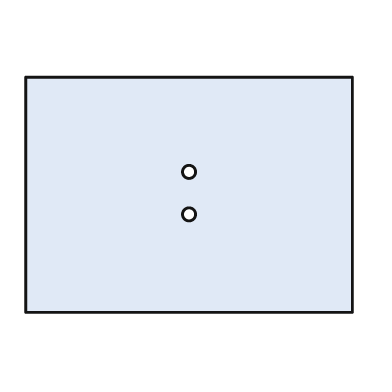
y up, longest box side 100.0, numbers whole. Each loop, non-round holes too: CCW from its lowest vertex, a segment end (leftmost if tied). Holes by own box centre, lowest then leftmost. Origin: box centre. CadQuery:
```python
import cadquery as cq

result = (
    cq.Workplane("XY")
    .moveTo(-50.0, -36.0)
    .lineTo(50.0, -36.0)
    .lineTo(50.0, 36.0)
    .lineTo(-50.0, 36.0)
    .close()
    .moveTo(0.0, -6.0)
    .circle(2.0)
    .moveTo(0.0, 7.0)
    .circle(2.0)
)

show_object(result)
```